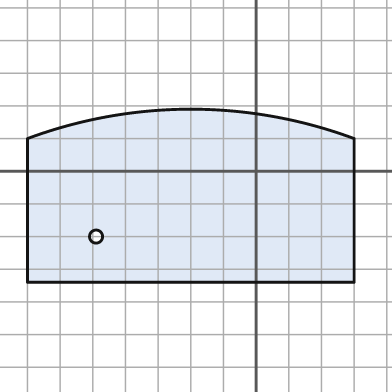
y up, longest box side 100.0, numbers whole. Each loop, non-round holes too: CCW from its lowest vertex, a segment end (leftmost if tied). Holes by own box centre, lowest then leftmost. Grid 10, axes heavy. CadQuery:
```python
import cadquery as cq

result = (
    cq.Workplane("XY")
    .moveTo(-70.0, -34.0)
    .lineTo(30.0, -34.0)
    .lineTo(30.0, 10.0)
    .threePointArc((-20.0, 19.0), (-70.0, 10.0))
    .close()
    .moveTo(-49.0, -20.0)
    .circle(2.0)
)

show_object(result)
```